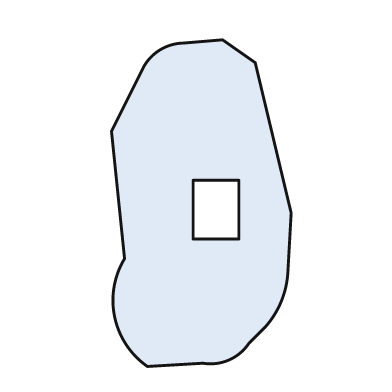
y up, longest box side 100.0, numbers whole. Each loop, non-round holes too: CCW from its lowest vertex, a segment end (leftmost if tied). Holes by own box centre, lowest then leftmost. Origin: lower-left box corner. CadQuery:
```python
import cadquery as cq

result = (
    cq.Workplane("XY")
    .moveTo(11.0, 0.0)
    .lineTo(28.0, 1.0)
    .threePointArc((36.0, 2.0), (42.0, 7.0))
    .lineTo(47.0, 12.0)
    .threePointArc((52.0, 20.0), (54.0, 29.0))
    .lineTo(55.0, 47.0)
    .lineTo(44.0, 93.0)
    .lineTo(34.0, 100.0)
    .lineTo(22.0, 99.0)
    .threePointArc((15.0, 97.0), (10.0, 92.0))
    .lineTo(0.0, 72.0)
    .lineTo(4.0, 33.0)
    .threePointArc((1.0, 15.0), (11.0, 0.0))
    .close()
    .moveTo(25.0, 39.0)
    .lineTo(39.0, 39.0)
    .lineTo(39.0, 57.0)
    .lineTo(25.0, 57.0)
    .close()
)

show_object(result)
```